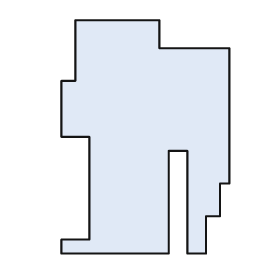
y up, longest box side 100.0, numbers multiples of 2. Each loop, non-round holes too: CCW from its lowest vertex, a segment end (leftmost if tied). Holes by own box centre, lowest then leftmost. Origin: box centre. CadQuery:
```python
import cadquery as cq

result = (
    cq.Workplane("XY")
    .moveTo(-36.0, -50.0)
    .lineTo(10.0, -50.0)
    .lineTo(10.0, -6.0)
    .lineTo(18.0, -6.0)
    .lineTo(18.0, -50.0)
    .lineTo(26.0, -50.0)
    .lineTo(26.0, -34.0)
    .lineTo(32.0, -34.0)
    .lineTo(32.0, -20.0)
    .lineTo(36.0, -20.0)
    .lineTo(36.0, 38.0)
    .lineTo(6.0, 38.0)
    .lineTo(6.0, 50.0)
    .lineTo(-30.0, 50.0)
    .lineTo(-30.0, 24.0)
    .lineTo(-36.0, 24.0)
    .lineTo(-36.0, 0.0)
    .lineTo(-24.0, 0.0)
    .lineTo(-24.0, -44.0)
    .lineTo(-36.0, -44.0)
    .close()
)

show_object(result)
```